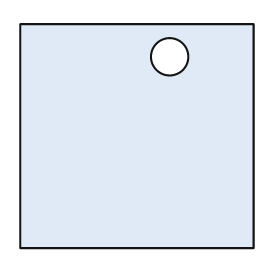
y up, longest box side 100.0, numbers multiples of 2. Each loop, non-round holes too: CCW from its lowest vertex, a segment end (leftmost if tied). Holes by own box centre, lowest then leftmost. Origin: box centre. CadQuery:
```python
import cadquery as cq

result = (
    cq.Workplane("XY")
    .moveTo(-50.0, -48.0)
    .lineTo(50.0, -48.0)
    .lineTo(50.0, 48.0)
    .lineTo(-50.0, 48.0)
    .close()
    .moveTo(14.0, 34.0)
    .circle(8.0)
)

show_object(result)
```